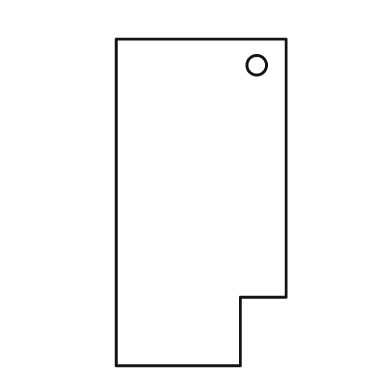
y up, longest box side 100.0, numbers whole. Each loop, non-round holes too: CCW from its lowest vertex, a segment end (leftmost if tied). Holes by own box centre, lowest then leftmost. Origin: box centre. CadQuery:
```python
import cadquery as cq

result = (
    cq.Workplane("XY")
    .moveTo(-26.0, -50.0)
    .lineTo(12.0, -50.0)
    .lineTo(12.0, -29.0)
    .lineTo(26.0, -29.0)
    .lineTo(26.0, 50.0)
    .lineTo(-26.0, 50.0)
    .close()
    .moveTo(17.0, 42.0)
    .circle(3.0)
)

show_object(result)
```